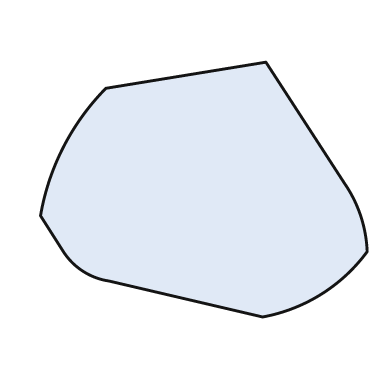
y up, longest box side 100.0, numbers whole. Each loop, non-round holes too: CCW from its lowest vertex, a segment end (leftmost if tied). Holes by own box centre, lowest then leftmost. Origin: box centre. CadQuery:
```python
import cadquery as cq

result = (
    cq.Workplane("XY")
    .moveTo(18.0, -39.0)
    .threePointArc((36.0, -32.0), (50.0, -19.0))
    .threePointArc((48.0, -8.0), (43.0, 2.0))
    .lineTo(19.0, 39.0)
    .lineTo(-30.0, 31.0)
    .threePointArc((-43.0, 13.0), (-50.0, -8.0))
    .lineTo(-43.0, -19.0)
    .threePointArc((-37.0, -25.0), (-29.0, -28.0))
    .close()
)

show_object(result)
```